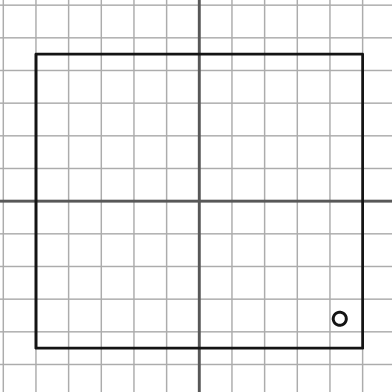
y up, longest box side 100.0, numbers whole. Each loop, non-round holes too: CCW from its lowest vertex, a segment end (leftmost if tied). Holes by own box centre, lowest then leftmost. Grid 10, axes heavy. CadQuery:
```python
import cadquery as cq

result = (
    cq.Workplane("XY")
    .moveTo(-50.0, -45.0)
    .lineTo(50.0, -45.0)
    .lineTo(50.0, 45.0)
    .lineTo(-50.0, 45.0)
    .close()
    .moveTo(43.0, -36.0)
    .circle(2.0)
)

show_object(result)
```